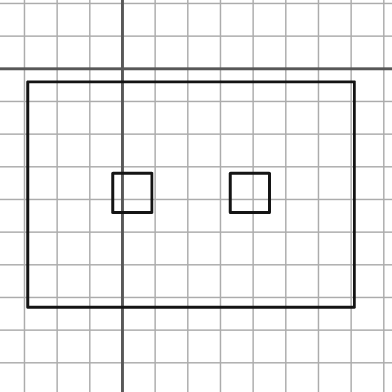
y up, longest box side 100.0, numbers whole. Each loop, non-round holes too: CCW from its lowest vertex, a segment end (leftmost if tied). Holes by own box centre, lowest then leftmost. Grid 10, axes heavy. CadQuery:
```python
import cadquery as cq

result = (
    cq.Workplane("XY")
    .moveTo(-29.0, -73.0)
    .lineTo(71.0, -73.0)
    .lineTo(71.0, -4.0)
    .lineTo(-29.0, -4.0)
    .close()
    .moveTo(-3.0, -44.0)
    .lineTo(9.0, -44.0)
    .lineTo(9.0, -32.0)
    .lineTo(-3.0, -32.0)
    .close()
    .moveTo(33.0, -44.0)
    .lineTo(45.0, -44.0)
    .lineTo(45.0, -32.0)
    .lineTo(33.0, -32.0)
    .close()
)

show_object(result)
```